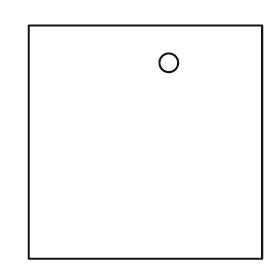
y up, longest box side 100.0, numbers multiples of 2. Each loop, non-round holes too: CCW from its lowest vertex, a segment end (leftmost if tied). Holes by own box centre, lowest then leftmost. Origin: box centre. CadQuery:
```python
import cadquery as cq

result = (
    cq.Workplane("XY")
    .moveTo(-50.0, -50.0)
    .lineTo(50.0, -50.0)
    .lineTo(50.0, 50.0)
    .lineTo(-50.0, 50.0)
    .close()
    .moveTo(10.0, 34.0)
    .circle(4.0)
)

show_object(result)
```